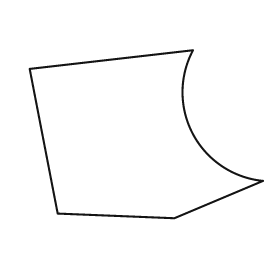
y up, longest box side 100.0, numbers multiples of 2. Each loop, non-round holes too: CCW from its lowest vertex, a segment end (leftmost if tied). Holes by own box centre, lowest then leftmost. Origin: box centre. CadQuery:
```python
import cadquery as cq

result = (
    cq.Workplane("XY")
    .moveTo(12.0, -36.0)
    .lineTo(50.0, -20.0)
    .threePointArc((20.0, 0.0), (20.0, 36.0))
    .lineTo(-50.0, 28.0)
    .lineTo(-38.0, -34.0)
    .close()
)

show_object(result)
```